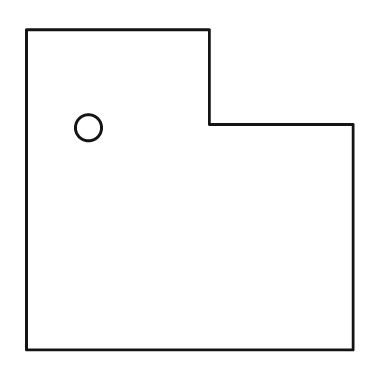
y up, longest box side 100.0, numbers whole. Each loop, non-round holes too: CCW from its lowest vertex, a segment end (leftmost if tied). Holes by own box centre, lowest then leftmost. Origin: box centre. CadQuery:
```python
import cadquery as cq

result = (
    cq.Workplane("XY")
    .moveTo(-50.0, -49.0)
    .lineTo(50.0, -49.0)
    .lineTo(50.0, 20.0)
    .lineTo(6.0, 20.0)
    .lineTo(6.0, 49.0)
    .lineTo(-50.0, 49.0)
    .close()
    .moveTo(-31.0, 19.0)
    .circle(4.0)
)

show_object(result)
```